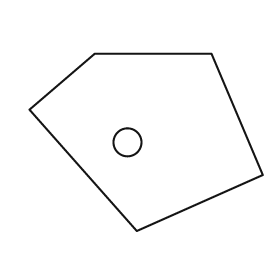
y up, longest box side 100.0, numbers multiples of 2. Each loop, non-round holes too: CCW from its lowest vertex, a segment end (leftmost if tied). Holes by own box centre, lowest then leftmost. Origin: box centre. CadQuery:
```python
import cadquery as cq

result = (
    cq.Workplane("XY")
    .moveTo(-4.0, -38.0)
    .lineTo(50.0, -14.0)
    .lineTo(28.0, 38.0)
    .lineTo(-22.0, 38.0)
    .lineTo(-50.0, 14.0)
    .close()
    .moveTo(-8.0, 0.0)
    .circle(6.0)
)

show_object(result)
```